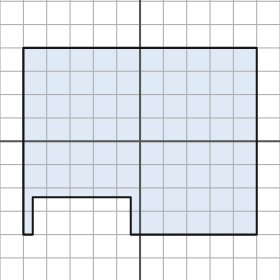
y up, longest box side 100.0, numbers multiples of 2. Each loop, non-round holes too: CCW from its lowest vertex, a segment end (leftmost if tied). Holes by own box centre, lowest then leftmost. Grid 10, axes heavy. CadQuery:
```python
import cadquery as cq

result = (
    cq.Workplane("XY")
    .moveTo(-50.0, -40.0)
    .lineTo(-46.0, -40.0)
    .lineTo(-46.0, -24.0)
    .lineTo(-4.0, -24.0)
    .lineTo(-4.0, -40.0)
    .lineTo(50.0, -40.0)
    .lineTo(50.0, 40.0)
    .lineTo(-50.0, 40.0)
    .close()
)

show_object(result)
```